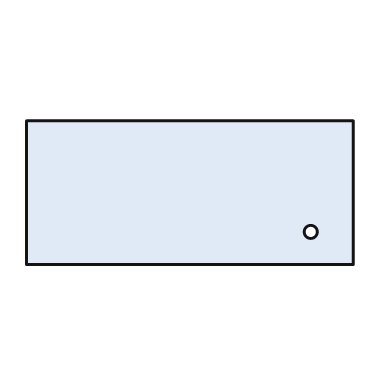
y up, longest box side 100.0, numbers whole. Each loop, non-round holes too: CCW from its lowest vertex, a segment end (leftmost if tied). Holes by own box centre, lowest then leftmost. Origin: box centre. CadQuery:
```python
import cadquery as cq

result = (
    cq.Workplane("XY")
    .moveTo(-50.0, -22.0)
    .lineTo(50.0, -22.0)
    .lineTo(50.0, 22.0)
    .lineTo(-50.0, 22.0)
    .close()
    .moveTo(37.0, -12.0)
    .circle(2.0)
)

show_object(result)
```